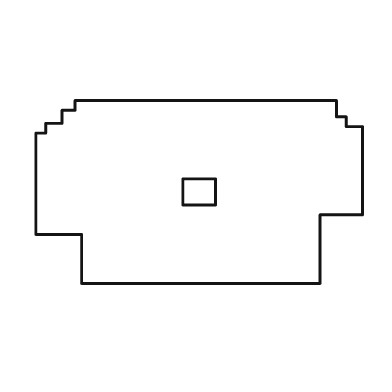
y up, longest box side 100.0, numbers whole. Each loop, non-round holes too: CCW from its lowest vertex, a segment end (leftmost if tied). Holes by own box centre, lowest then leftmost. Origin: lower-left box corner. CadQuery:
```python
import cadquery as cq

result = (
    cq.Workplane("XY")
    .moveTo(14.0, 0.0)
    .lineTo(87.0, 0.0)
    .lineTo(87.0, 21.0)
    .lineTo(100.0, 21.0)
    .lineTo(100.0, 48.0)
    .lineTo(95.0, 48.0)
    .lineTo(95.0, 51.0)
    .lineTo(92.0, 51.0)
    .lineTo(92.0, 56.0)
    .lineTo(12.0, 56.0)
    .lineTo(12.0, 53.0)
    .lineTo(8.0, 53.0)
    .lineTo(8.0, 49.0)
    .lineTo(3.0, 49.0)
    .lineTo(3.0, 46.0)
    .lineTo(0.0, 46.0)
    .lineTo(0.0, 15.0)
    .lineTo(14.0, 15.0)
    .close()
    .moveTo(45.0, 24.0)
    .lineTo(55.0, 24.0)
    .lineTo(55.0, 32.0)
    .lineTo(45.0, 32.0)
    .close()
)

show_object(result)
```